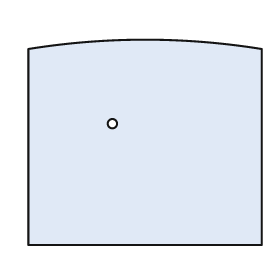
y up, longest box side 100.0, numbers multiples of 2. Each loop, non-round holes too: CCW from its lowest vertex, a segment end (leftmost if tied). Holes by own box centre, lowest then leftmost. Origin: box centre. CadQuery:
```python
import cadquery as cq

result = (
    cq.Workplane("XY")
    .moveTo(-50.0, -44.0)
    .lineTo(50.0, -44.0)
    .lineTo(50.0, 40.0)
    .threePointArc((0.0, 44.0), (-50.0, 40.0))
    .close()
    .moveTo(-14.0, 8.0)
    .circle(2.0)
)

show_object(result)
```